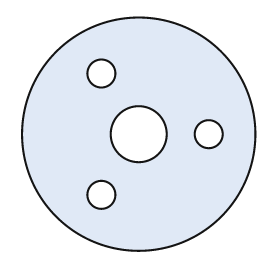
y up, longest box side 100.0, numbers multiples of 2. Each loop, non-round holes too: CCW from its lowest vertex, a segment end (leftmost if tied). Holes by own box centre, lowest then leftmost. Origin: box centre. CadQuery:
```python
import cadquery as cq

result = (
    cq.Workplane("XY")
    .moveTo(0.0, 0.0)
    .circle(50.0)
    .moveTo(-16.0, -26.0)
    .circle(6.0)
    .moveTo(0.0, 0.0)
    .circle(12.0)
    .moveTo(30.0, 0.0)
    .circle(6.0)
    .moveTo(-16.0, 26.0)
    .circle(6.0)
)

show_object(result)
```